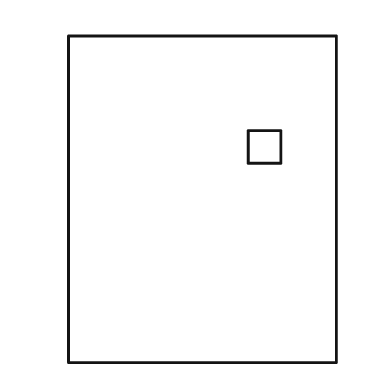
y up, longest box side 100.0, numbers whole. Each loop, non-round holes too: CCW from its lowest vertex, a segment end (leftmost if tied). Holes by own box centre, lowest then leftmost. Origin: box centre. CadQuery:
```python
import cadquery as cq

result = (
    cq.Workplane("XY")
    .moveTo(-41.0, -50.0)
    .lineTo(41.0, -50.0)
    .lineTo(41.0, 50.0)
    .lineTo(-41.0, 50.0)
    .close()
    .moveTo(14.0, 11.0)
    .lineTo(24.0, 11.0)
    .lineTo(24.0, 21.0)
    .lineTo(14.0, 21.0)
    .close()
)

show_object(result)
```